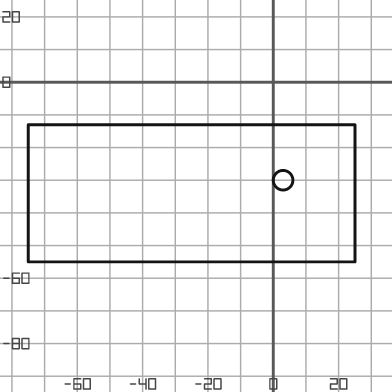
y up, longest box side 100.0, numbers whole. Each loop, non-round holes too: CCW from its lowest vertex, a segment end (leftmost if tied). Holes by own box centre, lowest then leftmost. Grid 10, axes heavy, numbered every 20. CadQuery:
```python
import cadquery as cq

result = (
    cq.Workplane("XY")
    .moveTo(-75.0, -55.0)
    .lineTo(25.0, -55.0)
    .lineTo(25.0, -13.0)
    .lineTo(-75.0, -13.0)
    .close()
    .moveTo(3.0, -30.0)
    .circle(3.0)
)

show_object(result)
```